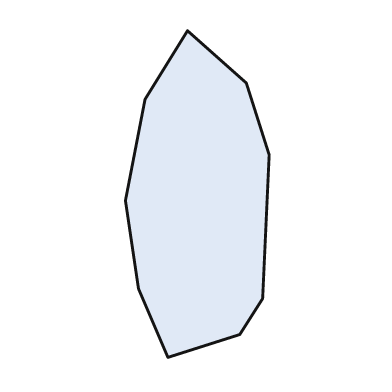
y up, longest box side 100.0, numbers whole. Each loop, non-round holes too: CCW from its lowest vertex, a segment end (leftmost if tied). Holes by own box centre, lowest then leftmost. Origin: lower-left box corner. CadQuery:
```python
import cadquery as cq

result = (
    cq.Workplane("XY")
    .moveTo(13.0, 0.0)
    .lineTo(35.0, 7.0)
    .lineTo(42.0, 18.0)
    .lineTo(44.0, 62.0)
    .lineTo(37.0, 84.0)
    .lineTo(19.0, 100.0)
    .lineTo(6.0, 79.0)
    .lineTo(0.0, 48.0)
    .lineTo(4.0, 21.0)
    .close()
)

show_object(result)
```